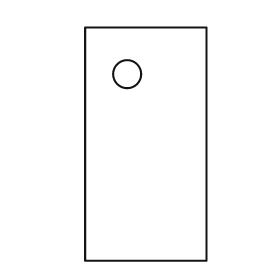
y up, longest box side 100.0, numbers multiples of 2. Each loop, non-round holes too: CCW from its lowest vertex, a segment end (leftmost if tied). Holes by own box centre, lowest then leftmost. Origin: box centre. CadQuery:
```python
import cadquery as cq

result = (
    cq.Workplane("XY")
    .moveTo(-26.0, -50.0)
    .lineTo(26.0, -50.0)
    .lineTo(26.0, 50.0)
    .lineTo(-26.0, 50.0)
    .close()
    .moveTo(-8.0, 30.0)
    .circle(6.0)
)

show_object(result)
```